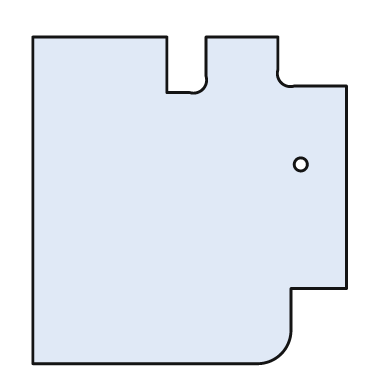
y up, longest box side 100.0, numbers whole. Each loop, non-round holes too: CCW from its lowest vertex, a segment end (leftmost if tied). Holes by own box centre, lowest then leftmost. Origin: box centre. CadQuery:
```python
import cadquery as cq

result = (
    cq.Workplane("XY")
    .moveTo(-48.0, -50.0)
    .lineTo(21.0, -50.0)
    .threePointArc((28.0, -47.0), (31.0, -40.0))
    .lineTo(31.0, -27.0)
    .lineTo(48.0, -27.0)
    .lineTo(48.0, 35.0)
    .lineTo(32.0, 35.0)
    .threePointArc((28.0, 36.0), (27.0, 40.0))
    .lineTo(27.0, 50.0)
    .lineTo(5.0, 50.0)
    .lineTo(5.0, 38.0)
    .threePointArc((4.0, 34.0), (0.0, 33.0))
    .lineTo(-7.0, 33.0)
    .lineTo(-7.0, 50.0)
    .lineTo(-48.0, 50.0)
    .close()
    .moveTo(34.0, 11.0)
    .circle(2.0)
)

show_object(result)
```